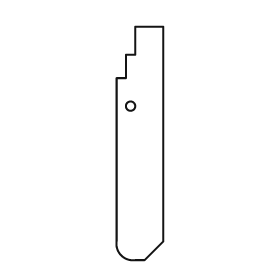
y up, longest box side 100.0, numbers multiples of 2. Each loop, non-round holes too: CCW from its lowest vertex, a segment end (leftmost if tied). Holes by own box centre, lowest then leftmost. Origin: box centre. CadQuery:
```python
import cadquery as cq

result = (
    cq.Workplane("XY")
    .moveTo(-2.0, -50.0)
    .lineTo(2.0, -50.0)
    .lineTo(10.0, -42.0)
    .lineTo(10.0, 50.0)
    .lineTo(-2.0, 50.0)
    .lineTo(-2.0, 38.0)
    .lineTo(-6.0, 38.0)
    .lineTo(-6.0, 28.0)
    .lineTo(-10.0, 28.0)
    .lineTo(-10.0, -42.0)
    .threePointArc((-8.0, -48.0), (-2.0, -50.0))
    .close()
    .moveTo(-4.0, 16.0)
    .circle(2.0)
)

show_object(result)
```